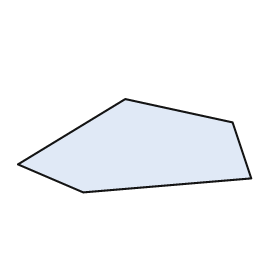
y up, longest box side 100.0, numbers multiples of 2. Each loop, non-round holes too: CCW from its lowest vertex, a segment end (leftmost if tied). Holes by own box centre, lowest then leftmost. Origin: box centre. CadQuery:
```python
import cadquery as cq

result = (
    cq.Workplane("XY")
    .moveTo(-22.0, -20.0)
    .lineTo(50.0, -14.0)
    .lineTo(42.0, 10.0)
    .lineTo(-4.0, 20.0)
    .lineTo(-50.0, -8.0)
    .close()
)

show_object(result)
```